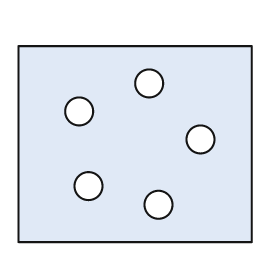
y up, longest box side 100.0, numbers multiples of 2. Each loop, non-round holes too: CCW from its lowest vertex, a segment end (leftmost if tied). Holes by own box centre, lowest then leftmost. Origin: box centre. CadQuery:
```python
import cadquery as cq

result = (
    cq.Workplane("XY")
    .moveTo(-50.0, -42.0)
    .lineTo(50.0, -42.0)
    .lineTo(50.0, 42.0)
    .lineTo(-50.0, 42.0)
    .close()
    .moveTo(10.0, -26.0)
    .circle(6.0)
    .moveTo(-20.0, -18.0)
    .circle(6.0)
    .moveTo(28.0, 2.0)
    .circle(6.0)
    .moveTo(-24.0, 14.0)
    .circle(6.0)
    .moveTo(6.0, 26.0)
    .circle(6.0)
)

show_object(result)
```